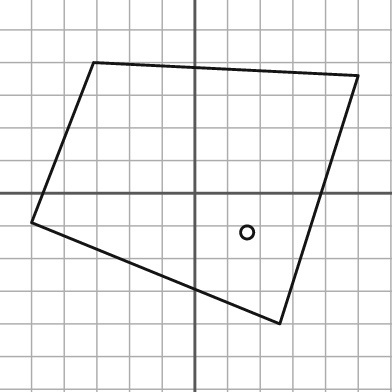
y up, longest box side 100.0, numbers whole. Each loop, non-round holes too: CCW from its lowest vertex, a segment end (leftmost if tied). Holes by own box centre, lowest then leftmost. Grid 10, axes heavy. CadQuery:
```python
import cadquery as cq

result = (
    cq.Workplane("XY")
    .moveTo(26.0, -40.0)
    .lineTo(50.0, 36.0)
    .lineTo(-31.0, 40.0)
    .lineTo(-50.0, -9.0)
    .close()
    .moveTo(16.0, -12.0)
    .circle(2.0)
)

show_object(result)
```